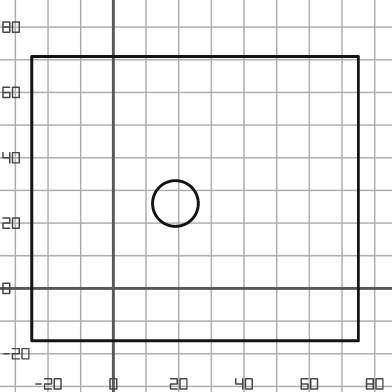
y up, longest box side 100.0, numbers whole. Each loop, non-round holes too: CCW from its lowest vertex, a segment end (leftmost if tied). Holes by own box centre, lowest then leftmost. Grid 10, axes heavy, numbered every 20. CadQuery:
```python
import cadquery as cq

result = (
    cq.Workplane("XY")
    .moveTo(-25.0, -16.0)
    .lineTo(75.0, -16.0)
    .lineTo(75.0, 71.0)
    .lineTo(-25.0, 71.0)
    .close()
    .moveTo(19.0, 26.0)
    .circle(7.0)
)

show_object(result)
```